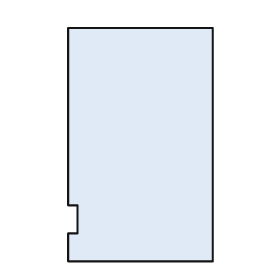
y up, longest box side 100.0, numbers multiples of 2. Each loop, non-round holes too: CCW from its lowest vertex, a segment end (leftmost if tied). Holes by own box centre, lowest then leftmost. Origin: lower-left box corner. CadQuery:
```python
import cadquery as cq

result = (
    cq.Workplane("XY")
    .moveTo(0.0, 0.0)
    .lineTo(62.0, 0.0)
    .lineTo(62.0, 100.0)
    .lineTo(0.0, 100.0)
    .lineTo(0.0, 24.0)
    .lineTo(4.0, 24.0)
    .lineTo(4.0, 12.0)
    .lineTo(0.0, 12.0)
    .close()
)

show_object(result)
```